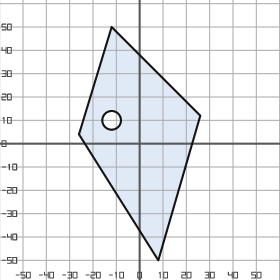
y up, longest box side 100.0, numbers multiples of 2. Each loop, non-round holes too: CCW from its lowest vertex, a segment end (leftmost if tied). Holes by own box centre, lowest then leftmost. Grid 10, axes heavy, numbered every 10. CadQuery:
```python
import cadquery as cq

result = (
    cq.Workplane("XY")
    .moveTo(8.0, -50.0)
    .lineTo(26.0, 12.0)
    .lineTo(-12.0, 50.0)
    .lineTo(-26.0, 4.0)
    .close()
    .moveTo(-12.0, 10.0)
    .circle(4.0)
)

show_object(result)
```